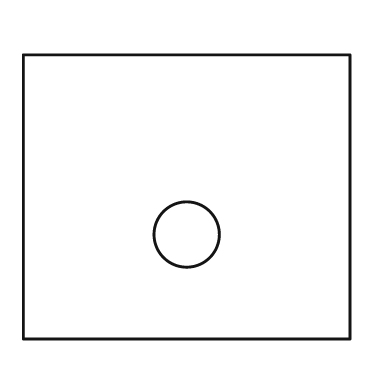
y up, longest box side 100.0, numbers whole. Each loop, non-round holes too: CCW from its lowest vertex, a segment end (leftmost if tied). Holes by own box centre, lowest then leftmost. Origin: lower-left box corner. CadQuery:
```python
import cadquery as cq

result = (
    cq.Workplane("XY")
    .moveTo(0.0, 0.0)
    .lineTo(100.0, 0.0)
    .lineTo(100.0, 87.0)
    .lineTo(0.0, 87.0)
    .close()
    .moveTo(50.0, 32.0)
    .circle(10.0)
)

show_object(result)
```